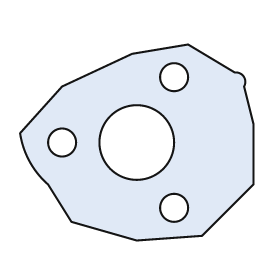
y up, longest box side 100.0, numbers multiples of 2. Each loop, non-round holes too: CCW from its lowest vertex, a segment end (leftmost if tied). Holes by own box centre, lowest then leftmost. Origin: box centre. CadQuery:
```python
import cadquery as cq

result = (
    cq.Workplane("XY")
    .moveTo(0.0, -42.0)
    .lineTo(28.0, -40.0)
    .lineTo(50.0, -18.0)
    .lineTo(50.0, 8.0)
    .lineTo(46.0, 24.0)
    .threePointArc((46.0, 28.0), (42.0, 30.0))
    .lineTo(22.0, 42.0)
    .lineTo(-2.0, 38.0)
    .lineTo(-32.0, 24.0)
    .lineTo(-50.0, 4.0)
    .threePointArc((-46.0, -8.0), (-38.0, -18.0))
    .lineTo(-28.0, -34.0)
    .close()
    .moveTo(16.0, -28.0)
    .circle(6.0)
    .moveTo(-32.0, 0.0)
    .circle(6.0)
    .moveTo(0.0, 0.0)
    .circle(16.0)
    .moveTo(16.0, 28.0)
    .circle(6.0)
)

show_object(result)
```